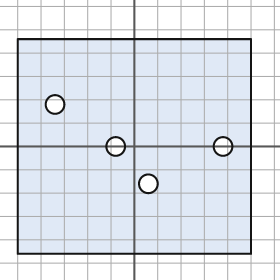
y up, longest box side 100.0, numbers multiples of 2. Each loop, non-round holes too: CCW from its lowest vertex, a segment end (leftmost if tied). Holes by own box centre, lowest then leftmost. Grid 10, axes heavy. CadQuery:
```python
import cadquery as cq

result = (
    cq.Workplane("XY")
    .moveTo(-50.0, -46.0)
    .lineTo(50.0, -46.0)
    .lineTo(50.0, 46.0)
    .lineTo(-50.0, 46.0)
    .close()
    .moveTo(6.0, -16.0)
    .circle(4.0)
    .moveTo(-8.0, 0.0)
    .circle(4.0)
    .moveTo(38.0, 0.0)
    .circle(4.0)
    .moveTo(-34.0, 18.0)
    .circle(4.0)
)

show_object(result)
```